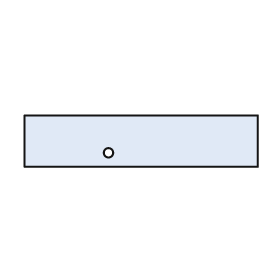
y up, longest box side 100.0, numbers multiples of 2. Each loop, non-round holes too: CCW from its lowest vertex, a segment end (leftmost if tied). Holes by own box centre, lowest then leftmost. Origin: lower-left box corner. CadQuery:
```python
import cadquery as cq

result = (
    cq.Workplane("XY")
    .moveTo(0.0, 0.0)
    .lineTo(100.0, 0.0)
    .lineTo(100.0, 22.0)
    .lineTo(0.0, 22.0)
    .close()
    .moveTo(36.0, 6.0)
    .circle(2.0)
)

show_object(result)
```